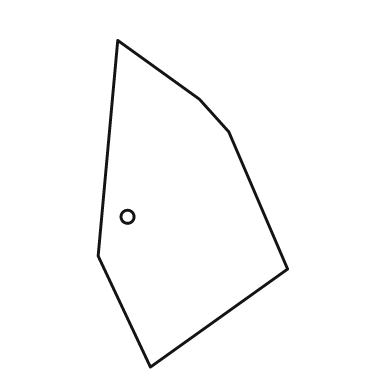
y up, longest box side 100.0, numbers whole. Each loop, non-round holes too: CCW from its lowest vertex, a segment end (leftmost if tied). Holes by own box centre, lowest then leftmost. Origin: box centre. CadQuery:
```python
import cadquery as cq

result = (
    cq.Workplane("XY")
    .moveTo(-13.0, -50.0)
    .lineTo(29.0, -20.0)
    .lineTo(11.0, 22.0)
    .lineTo(2.0, 32.0)
    .lineTo(-23.0, 50.0)
    .lineTo(-29.0, -16.0)
    .close()
    .moveTo(-20.0, -4.0)
    .circle(2.0)
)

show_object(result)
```